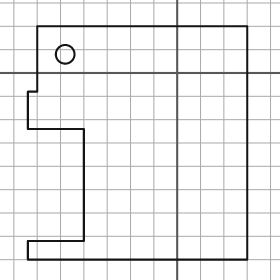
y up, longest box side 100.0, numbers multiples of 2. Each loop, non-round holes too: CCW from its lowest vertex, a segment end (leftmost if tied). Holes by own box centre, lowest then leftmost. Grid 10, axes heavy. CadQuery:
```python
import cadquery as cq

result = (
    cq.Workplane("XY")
    .moveTo(-64.0, -80.0)
    .lineTo(30.0, -80.0)
    .lineTo(30.0, 20.0)
    .lineTo(-60.0, 20.0)
    .lineTo(-60.0, -8.0)
    .lineTo(-64.0, -8.0)
    .lineTo(-64.0, -24.0)
    .lineTo(-40.0, -24.0)
    .lineTo(-40.0, -72.0)
    .lineTo(-64.0, -72.0)
    .close()
    .moveTo(-48.0, 8.0)
    .circle(4.0)
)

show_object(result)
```